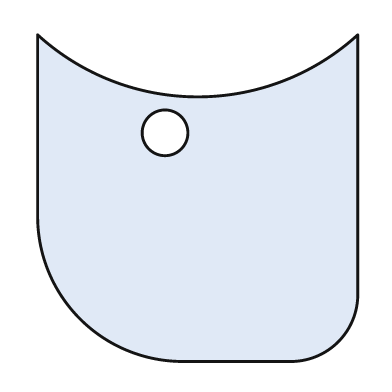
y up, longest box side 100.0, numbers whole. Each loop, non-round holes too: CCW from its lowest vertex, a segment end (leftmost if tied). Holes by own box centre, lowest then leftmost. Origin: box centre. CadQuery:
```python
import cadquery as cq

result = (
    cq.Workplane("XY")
    .moveTo(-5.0, -50.0)
    .lineTo(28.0, -50.0)
    .threePointArc((43.0, -44.0), (49.0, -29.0))
    .lineTo(49.0, 50.0)
    .threePointArc((0.0, 31.0), (-49.0, 50.0))
    .lineTo(-49.0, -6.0)
    .threePointArc((-36.0, -37.0), (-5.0, -50.0))
    .close()
    .moveTo(-10.0, 20.0)
    .circle(7.0)
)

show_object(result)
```